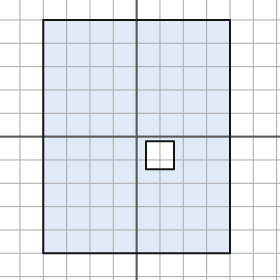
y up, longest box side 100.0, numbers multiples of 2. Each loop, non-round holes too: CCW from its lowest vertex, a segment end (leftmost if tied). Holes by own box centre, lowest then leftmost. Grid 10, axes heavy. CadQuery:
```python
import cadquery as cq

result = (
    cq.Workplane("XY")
    .moveTo(-40.0, -50.0)
    .lineTo(40.0, -50.0)
    .lineTo(40.0, 50.0)
    .lineTo(-40.0, 50.0)
    .close()
    .moveTo(4.0, -14.0)
    .lineTo(16.0, -14.0)
    .lineTo(16.0, -2.0)
    .lineTo(4.0, -2.0)
    .close()
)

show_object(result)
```